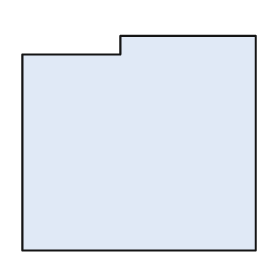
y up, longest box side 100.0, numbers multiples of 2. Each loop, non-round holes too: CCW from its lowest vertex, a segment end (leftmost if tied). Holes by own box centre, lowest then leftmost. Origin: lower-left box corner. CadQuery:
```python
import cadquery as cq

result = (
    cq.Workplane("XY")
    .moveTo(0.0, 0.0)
    .lineTo(100.0, 0.0)
    .lineTo(100.0, 92.0)
    .lineTo(42.0, 92.0)
    .lineTo(42.0, 84.0)
    .lineTo(0.0, 84.0)
    .close()
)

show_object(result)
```